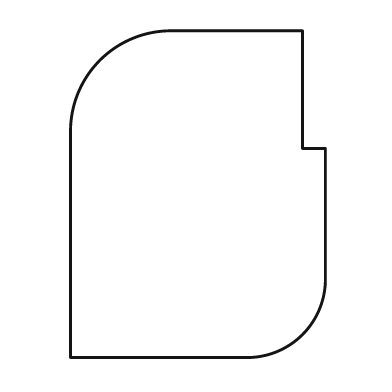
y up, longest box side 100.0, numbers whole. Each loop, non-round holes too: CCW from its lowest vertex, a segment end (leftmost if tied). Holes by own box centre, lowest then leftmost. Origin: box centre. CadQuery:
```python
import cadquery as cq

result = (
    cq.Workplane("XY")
    .moveTo(-39.0, -50.0)
    .lineTo(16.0, -50.0)
    .threePointArc((32.0, -43.0), (39.0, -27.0))
    .lineTo(39.0, 14.0)
    .lineTo(32.0, 14.0)
    .lineTo(32.0, 50.0)
    .lineTo(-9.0, 50.0)
    .threePointArc((-30.0, 41.0), (-39.0, 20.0))
    .close()
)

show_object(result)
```